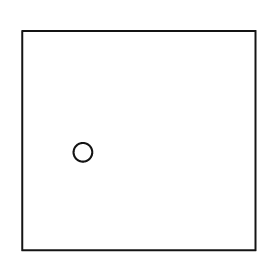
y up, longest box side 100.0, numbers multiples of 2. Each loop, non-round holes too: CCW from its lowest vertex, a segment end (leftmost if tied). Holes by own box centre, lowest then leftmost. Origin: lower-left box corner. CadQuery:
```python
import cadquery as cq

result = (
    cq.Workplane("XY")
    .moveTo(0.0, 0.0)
    .lineTo(100.0, 0.0)
    .lineTo(100.0, 94.0)
    .lineTo(0.0, 94.0)
    .close()
    .moveTo(26.0, 42.0)
    .circle(4.0)
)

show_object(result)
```